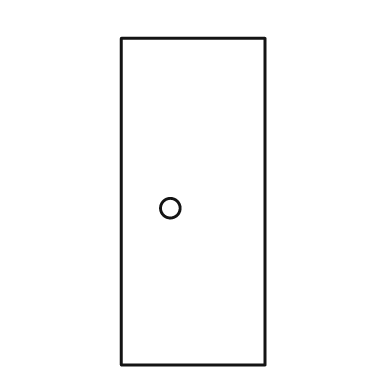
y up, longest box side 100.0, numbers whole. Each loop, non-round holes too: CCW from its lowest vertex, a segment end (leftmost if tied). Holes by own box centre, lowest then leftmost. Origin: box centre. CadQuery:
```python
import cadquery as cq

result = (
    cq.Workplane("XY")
    .moveTo(-22.0, -50.0)
    .lineTo(22.0, -50.0)
    .lineTo(22.0, 50.0)
    .lineTo(-22.0, 50.0)
    .close()
    .moveTo(-7.0, -2.0)
    .circle(3.0)
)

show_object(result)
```